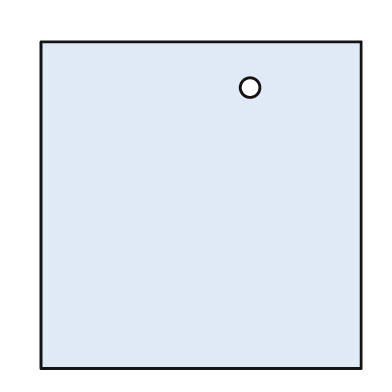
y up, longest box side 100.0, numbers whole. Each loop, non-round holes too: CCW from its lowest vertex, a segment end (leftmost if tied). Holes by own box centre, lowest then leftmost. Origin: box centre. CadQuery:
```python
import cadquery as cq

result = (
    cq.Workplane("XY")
    .moveTo(-49.0, -50.0)
    .lineTo(49.0, -50.0)
    .lineTo(49.0, 50.0)
    .lineTo(-49.0, 50.0)
    .close()
    .moveTo(15.0, 36.0)
    .circle(3.0)
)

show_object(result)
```